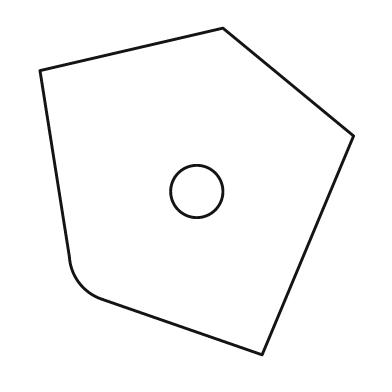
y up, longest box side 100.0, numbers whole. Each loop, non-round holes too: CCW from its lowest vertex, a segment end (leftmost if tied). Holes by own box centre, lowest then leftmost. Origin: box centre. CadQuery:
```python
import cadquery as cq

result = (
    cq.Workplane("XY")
    .moveTo(20.0, -50.0)
    .lineTo(48.0, 17.0)
    .lineTo(8.0, 50.0)
    .lineTo(-48.0, 37.0)
    .lineTo(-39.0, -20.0)
    .threePointArc((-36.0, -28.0), (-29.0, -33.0))
    .close()
    .moveTo(0.0, 0.0)
    .circle(8.0)
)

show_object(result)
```